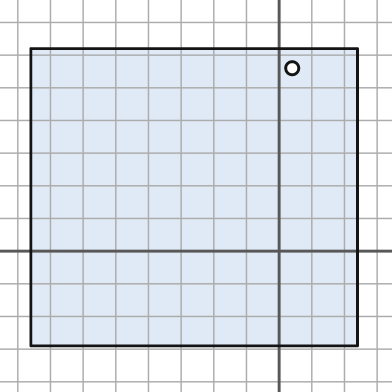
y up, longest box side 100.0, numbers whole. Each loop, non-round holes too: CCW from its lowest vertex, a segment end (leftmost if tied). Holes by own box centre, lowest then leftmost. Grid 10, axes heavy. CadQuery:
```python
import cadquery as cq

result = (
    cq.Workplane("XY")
    .moveTo(-76.0, -29.0)
    .lineTo(24.0, -29.0)
    .lineTo(24.0, 62.0)
    .lineTo(-76.0, 62.0)
    .close()
    .moveTo(4.0, 56.0)
    .circle(2.0)
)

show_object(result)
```